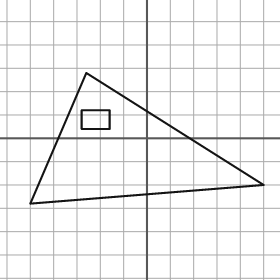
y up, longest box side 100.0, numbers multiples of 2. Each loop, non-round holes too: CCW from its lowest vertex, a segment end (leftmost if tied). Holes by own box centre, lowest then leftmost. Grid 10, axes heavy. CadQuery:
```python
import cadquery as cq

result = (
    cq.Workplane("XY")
    .moveTo(-50.0, -28.0)
    .lineTo(50.0, -20.0)
    .lineTo(-26.0, 28.0)
    .close()
    .moveTo(-28.0, 4.0)
    .lineTo(-16.0, 4.0)
    .lineTo(-16.0, 12.0)
    .lineTo(-28.0, 12.0)
    .close()
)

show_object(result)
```